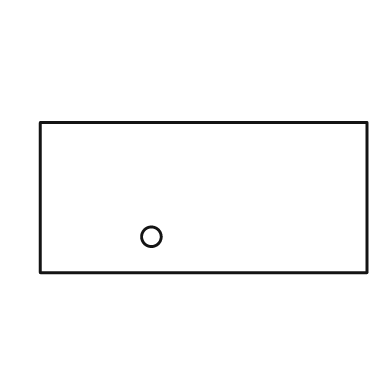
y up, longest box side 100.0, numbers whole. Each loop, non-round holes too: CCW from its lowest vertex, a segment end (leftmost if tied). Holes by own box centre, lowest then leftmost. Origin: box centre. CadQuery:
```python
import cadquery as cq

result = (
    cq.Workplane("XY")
    .moveTo(-50.0, -23.0)
    .lineTo(50.0, -23.0)
    .lineTo(50.0, 23.0)
    .lineTo(-50.0, 23.0)
    .close()
    .moveTo(-16.0, -12.0)
    .circle(3.0)
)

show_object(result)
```